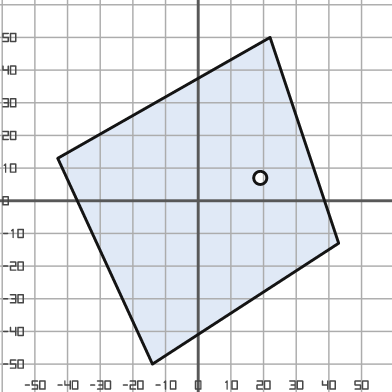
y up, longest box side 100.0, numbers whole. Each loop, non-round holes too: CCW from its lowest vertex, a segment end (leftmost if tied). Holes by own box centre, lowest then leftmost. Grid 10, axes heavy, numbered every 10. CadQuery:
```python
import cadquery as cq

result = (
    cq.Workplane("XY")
    .moveTo(-14.0, -50.0)
    .lineTo(43.0, -13.0)
    .lineTo(22.0, 50.0)
    .lineTo(-43.0, 13.0)
    .close()
    .moveTo(19.0, 7.0)
    .circle(2.0)
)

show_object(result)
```